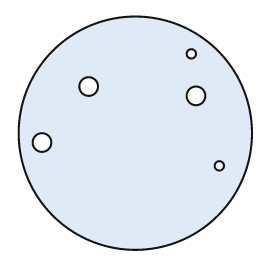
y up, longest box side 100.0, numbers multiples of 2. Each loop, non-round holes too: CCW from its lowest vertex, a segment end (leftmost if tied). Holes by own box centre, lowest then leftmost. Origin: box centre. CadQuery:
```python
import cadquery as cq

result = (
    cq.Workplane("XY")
    .moveTo(0.0, 0.0)
    .circle(50.0)
    .moveTo(36.0, -14.0)
    .circle(2.0)
    .moveTo(-40.0, -4.0)
    .circle(4.0)
    .moveTo(26.0, 16.0)
    .circle(4.0)
    .moveTo(-20.0, 20.0)
    .circle(4.0)
    .moveTo(24.0, 34.0)
    .circle(2.0)
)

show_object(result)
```